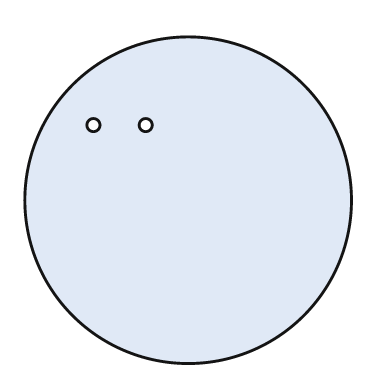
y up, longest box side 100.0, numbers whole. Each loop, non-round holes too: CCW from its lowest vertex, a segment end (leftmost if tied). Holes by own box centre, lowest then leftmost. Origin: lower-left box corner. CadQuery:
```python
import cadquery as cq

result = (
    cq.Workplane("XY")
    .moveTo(50.0, 50.0)
    .circle(50.0)
    .moveTo(21.0, 73.0)
    .circle(2.0)
    .moveTo(37.0, 73.0)
    .circle(2.0)
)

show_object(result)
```